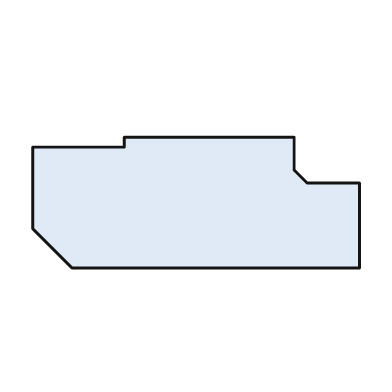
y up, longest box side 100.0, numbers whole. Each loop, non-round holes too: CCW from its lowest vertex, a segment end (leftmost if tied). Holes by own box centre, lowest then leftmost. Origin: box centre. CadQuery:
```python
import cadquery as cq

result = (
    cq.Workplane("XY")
    .moveTo(-38.0, -20.0)
    .lineTo(50.0, -20.0)
    .lineTo(50.0, 6.0)
    .lineTo(34.0, 6.0)
    .lineTo(30.0, 10.0)
    .lineTo(30.0, 20.0)
    .lineTo(-22.0, 20.0)
    .lineTo(-22.0, 17.0)
    .lineTo(-50.0, 17.0)
    .lineTo(-50.0, -8.0)
    .close()
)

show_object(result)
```